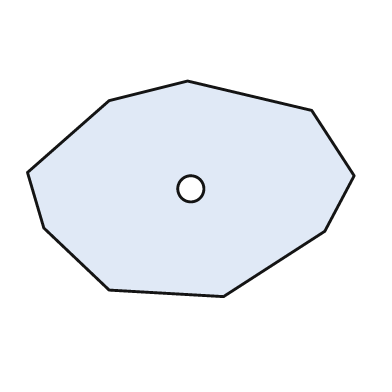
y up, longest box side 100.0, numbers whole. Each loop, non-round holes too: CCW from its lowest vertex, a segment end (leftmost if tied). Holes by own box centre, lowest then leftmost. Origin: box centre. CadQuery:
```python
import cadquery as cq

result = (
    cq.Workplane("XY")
    .moveTo(10.0, -33.0)
    .lineTo(41.0, -13.0)
    .lineTo(50.0, 4.0)
    .lineTo(37.0, 24.0)
    .lineTo(-1.0, 33.0)
    .lineTo(-25.0, 27.0)
    .lineTo(-50.0, 5.0)
    .lineTo(-45.0, -12.0)
    .lineTo(-25.0, -31.0)
    .close()
    .moveTo(0.0, 0.0)
    .circle(4.0)
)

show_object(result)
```